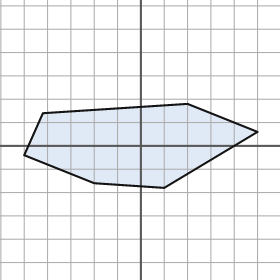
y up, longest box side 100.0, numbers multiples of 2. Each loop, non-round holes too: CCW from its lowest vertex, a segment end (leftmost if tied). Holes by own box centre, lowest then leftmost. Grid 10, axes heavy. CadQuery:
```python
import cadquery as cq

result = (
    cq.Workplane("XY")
    .moveTo(10.0, -18.0)
    .lineTo(50.0, 6.0)
    .lineTo(20.0, 18.0)
    .lineTo(-42.0, 14.0)
    .lineTo(-50.0, -4.0)
    .lineTo(-20.0, -16.0)
    .close()
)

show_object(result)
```